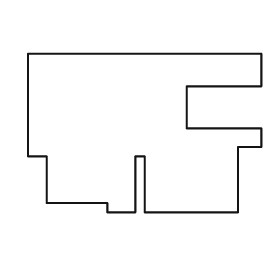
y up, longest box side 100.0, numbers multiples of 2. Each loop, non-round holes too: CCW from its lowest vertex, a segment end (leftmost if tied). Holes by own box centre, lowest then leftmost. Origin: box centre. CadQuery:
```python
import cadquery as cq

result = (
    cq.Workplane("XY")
    .moveTo(-16.0, -34.0)
    .lineTo(-4.0, -34.0)
    .lineTo(-4.0, -10.0)
    .lineTo(0.0, -10.0)
    .lineTo(0.0, -34.0)
    .lineTo(40.0, -34.0)
    .lineTo(40.0, -6.0)
    .lineTo(50.0, -6.0)
    .lineTo(50.0, 2.0)
    .lineTo(18.0, 2.0)
    .lineTo(18.0, 20.0)
    .lineTo(50.0, 20.0)
    .lineTo(50.0, 34.0)
    .lineTo(-50.0, 34.0)
    .lineTo(-50.0, -10.0)
    .lineTo(-42.0, -10.0)
    .lineTo(-42.0, -30.0)
    .lineTo(-16.0, -30.0)
    .close()
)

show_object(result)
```